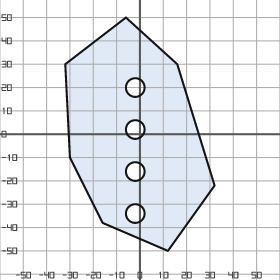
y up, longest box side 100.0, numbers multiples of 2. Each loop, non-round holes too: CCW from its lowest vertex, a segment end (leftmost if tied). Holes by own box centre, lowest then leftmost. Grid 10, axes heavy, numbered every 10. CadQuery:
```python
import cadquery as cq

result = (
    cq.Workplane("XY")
    .moveTo(12.0, -50.0)
    .lineTo(32.0, -22.0)
    .lineTo(16.0, 30.0)
    .lineTo(-6.0, 50.0)
    .lineTo(-32.0, 30.0)
    .lineTo(-30.0, -10.0)
    .lineTo(-16.0, -38.0)
    .close()
    .moveTo(-2.0, -34.0)
    .circle(4.0)
    .moveTo(-2.0, -16.0)
    .circle(4.0)
    .moveTo(-2.0, 2.0)
    .circle(4.0)
    .moveTo(-2.0, 20.0)
    .circle(4.0)
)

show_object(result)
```